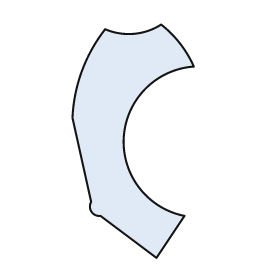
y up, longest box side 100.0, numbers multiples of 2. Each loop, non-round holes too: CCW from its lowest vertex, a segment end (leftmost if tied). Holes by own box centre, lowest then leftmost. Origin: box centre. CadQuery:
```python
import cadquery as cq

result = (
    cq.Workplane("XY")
    .moveTo(10.0, -50.0)
    .lineTo(22.0, -32.0)
    .threePointArc((-4.0, 2.0), (26.0, 32.0))
    .threePointArc((20.0, 42.0), (12.0, 50.0))
    .threePointArc((0.0, 46.0), (-12.0, 48.0))
    .threePointArc((-22.0, 30.0), (-26.0, 10.0))
    .lineTo(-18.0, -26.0)
    .threePointArc((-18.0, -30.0), (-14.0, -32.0))
    .close()
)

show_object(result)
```